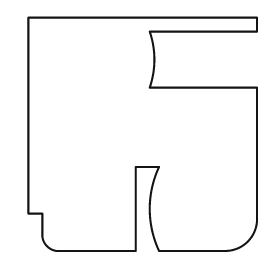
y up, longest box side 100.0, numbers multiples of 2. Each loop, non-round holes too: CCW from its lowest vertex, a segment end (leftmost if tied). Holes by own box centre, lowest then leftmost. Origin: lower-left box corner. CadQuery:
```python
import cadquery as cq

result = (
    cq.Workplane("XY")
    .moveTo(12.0, 0.0)
    .lineTo(46.0, 0.0)
    .lineTo(46.0, 36.0)
    .lineTo(56.0, 36.0)
    .threePointArc((52.0, 18.0), (56.0, 0.0))
    .lineTo(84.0, 0.0)
    .threePointArc((94.0, 4.0), (98.0, 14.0))
    .lineTo(98.0, 70.0)
    .lineTo(52.0, 70.0)
    .threePointArc((54.0, 82.0), (52.0, 94.0))
    .lineTo(98.0, 94.0)
    .lineTo(98.0, 100.0)
    .lineTo(0.0, 100.0)
    .lineTo(0.0, 16.0)
    .lineTo(6.0, 16.0)
    .lineTo(6.0, 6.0)
    .threePointArc((8.0, 2.0), (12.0, 0.0))
    .close()
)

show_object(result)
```